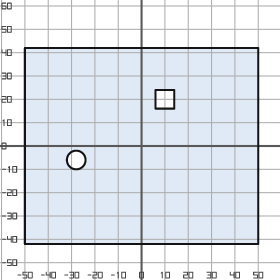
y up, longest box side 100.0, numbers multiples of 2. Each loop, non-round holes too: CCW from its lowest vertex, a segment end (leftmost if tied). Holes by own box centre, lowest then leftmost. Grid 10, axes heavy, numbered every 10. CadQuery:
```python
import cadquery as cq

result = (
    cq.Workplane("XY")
    .moveTo(-50.0, -42.0)
    .lineTo(50.0, -42.0)
    .lineTo(50.0, 42.0)
    .lineTo(-50.0, 42.0)
    .close()
    .moveTo(-28.0, -6.0)
    .circle(4.0)
    .moveTo(6.0, 16.0)
    .lineTo(14.0, 16.0)
    .lineTo(14.0, 24.0)
    .lineTo(6.0, 24.0)
    .close()
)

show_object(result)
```